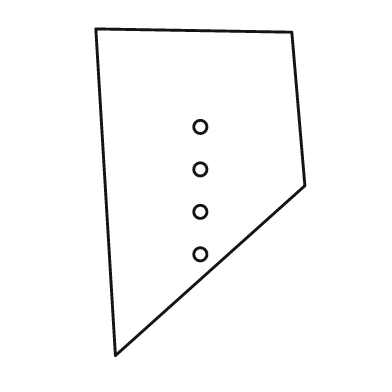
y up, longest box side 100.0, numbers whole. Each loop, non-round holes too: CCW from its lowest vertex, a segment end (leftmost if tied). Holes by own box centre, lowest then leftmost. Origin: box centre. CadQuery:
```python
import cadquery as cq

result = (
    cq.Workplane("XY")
    .moveTo(-26.0, -50.0)
    .lineTo(32.0, 2.0)
    .lineTo(28.0, 49.0)
    .lineTo(-32.0, 50.0)
    .close()
    .moveTo(0.0, -19.0)
    .circle(2.0)
    .moveTo(0.0, -6.0)
    .circle(2.0)
    .moveTo(0.0, 7.0)
    .circle(2.0)
    .moveTo(0.0, 20.0)
    .circle(2.0)
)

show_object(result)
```